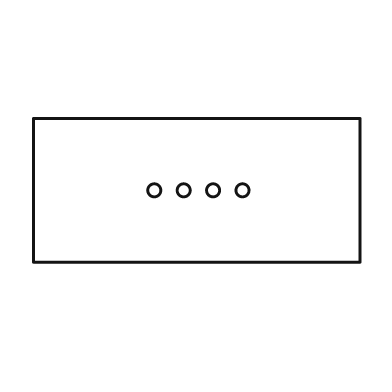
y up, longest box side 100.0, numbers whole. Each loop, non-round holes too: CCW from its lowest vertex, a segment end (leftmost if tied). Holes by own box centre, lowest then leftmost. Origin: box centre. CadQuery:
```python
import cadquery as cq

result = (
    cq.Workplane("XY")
    .moveTo(-50.0, -22.0)
    .lineTo(50.0, -22.0)
    .lineTo(50.0, 22.0)
    .lineTo(-50.0, 22.0)
    .close()
    .moveTo(-13.0, 0.0)
    .circle(2.0)
    .moveTo(-4.0, 0.0)
    .circle(2.0)
    .moveTo(5.0, 0.0)
    .circle(2.0)
    .moveTo(14.0, 0.0)
    .circle(2.0)
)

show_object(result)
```